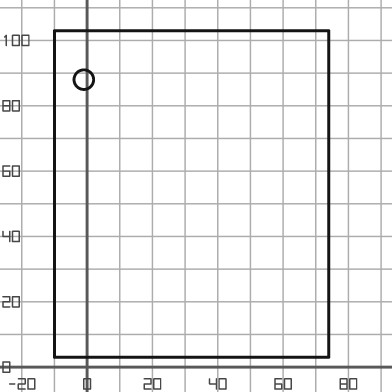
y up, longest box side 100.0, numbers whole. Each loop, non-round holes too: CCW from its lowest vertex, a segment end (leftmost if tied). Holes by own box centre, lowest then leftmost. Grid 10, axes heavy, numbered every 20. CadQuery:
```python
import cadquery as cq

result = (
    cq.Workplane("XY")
    .moveTo(-10.0, 3.0)
    .lineTo(74.0, 3.0)
    .lineTo(74.0, 103.0)
    .lineTo(-10.0, 103.0)
    .close()
    .moveTo(-1.0, 88.0)
    .circle(3.0)
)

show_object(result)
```